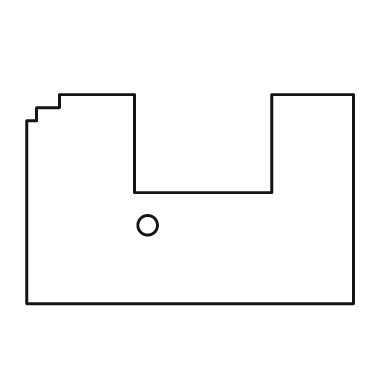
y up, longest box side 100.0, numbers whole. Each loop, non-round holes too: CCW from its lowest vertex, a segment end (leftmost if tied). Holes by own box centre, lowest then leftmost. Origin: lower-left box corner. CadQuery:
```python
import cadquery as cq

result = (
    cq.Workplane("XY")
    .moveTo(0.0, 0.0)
    .lineTo(100.0, 0.0)
    .lineTo(100.0, 64.0)
    .lineTo(75.0, 64.0)
    .lineTo(75.0, 34.0)
    .lineTo(33.0, 34.0)
    .lineTo(33.0, 64.0)
    .lineTo(10.0, 64.0)
    .lineTo(10.0, 60.0)
    .lineTo(3.0, 60.0)
    .lineTo(3.0, 56.0)
    .lineTo(0.0, 56.0)
    .close()
    .moveTo(37.0, 24.0)
    .circle(3.0)
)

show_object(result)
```